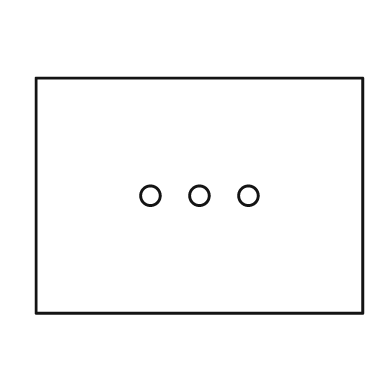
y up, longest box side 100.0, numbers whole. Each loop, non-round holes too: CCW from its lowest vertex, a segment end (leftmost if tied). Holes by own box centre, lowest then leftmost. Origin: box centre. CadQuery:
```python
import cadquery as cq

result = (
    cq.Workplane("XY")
    .moveTo(-50.0, -36.0)
    .lineTo(50.0, -36.0)
    .lineTo(50.0, 36.0)
    .lineTo(-50.0, 36.0)
    .close()
    .moveTo(-15.0, 0.0)
    .circle(3.0)
    .moveTo(0.0, 0.0)
    .circle(3.0)
    .moveTo(15.0, 0.0)
    .circle(3.0)
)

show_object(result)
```